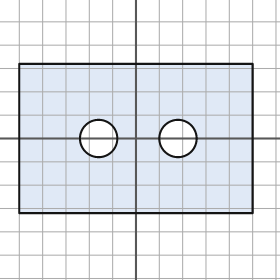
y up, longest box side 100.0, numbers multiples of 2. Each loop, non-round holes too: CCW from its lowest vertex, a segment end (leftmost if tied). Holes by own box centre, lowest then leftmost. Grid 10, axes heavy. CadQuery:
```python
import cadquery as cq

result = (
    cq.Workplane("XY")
    .moveTo(-50.0, -32.0)
    .lineTo(50.0, -32.0)
    .lineTo(50.0, 32.0)
    .lineTo(-50.0, 32.0)
    .close()
    .moveTo(-16.0, 0.0)
    .circle(8.0)
    .moveTo(18.0, 0.0)
    .circle(8.0)
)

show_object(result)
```